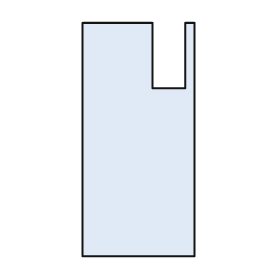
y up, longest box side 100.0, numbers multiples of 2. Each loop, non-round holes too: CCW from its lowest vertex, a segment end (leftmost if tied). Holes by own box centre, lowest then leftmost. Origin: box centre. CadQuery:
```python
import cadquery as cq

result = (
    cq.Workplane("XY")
    .moveTo(-24.0, -50.0)
    .lineTo(24.0, -50.0)
    .lineTo(24.0, 50.0)
    .lineTo(20.0, 50.0)
    .lineTo(20.0, 22.0)
    .lineTo(6.0, 22.0)
    .lineTo(6.0, 50.0)
    .lineTo(-24.0, 50.0)
    .close()
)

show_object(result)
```